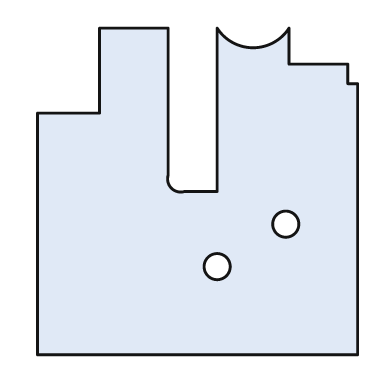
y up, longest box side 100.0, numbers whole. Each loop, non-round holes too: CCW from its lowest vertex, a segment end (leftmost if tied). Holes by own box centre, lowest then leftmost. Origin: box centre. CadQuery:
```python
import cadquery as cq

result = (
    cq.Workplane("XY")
    .moveTo(-49.0, -50.0)
    .lineTo(49.0, -50.0)
    .lineTo(49.0, 33.0)
    .lineTo(46.0, 33.0)
    .lineTo(46.0, 39.0)
    .lineTo(28.0, 39.0)
    .lineTo(28.0, 50.0)
    .threePointArc((17.0, 44.0), (6.0, 50.0))
    .lineTo(6.0, 0.0)
    .lineTo(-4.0, 0.0)
    .threePointArc((-8.0, 1.0), (-9.0, 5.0))
    .lineTo(-9.0, 50.0)
    .lineTo(-30.0, 50.0)
    .lineTo(-30.0, 24.0)
    .lineTo(-49.0, 24.0)
    .close()
    .moveTo(6.0, -23.0)
    .circle(4.0)
    .moveTo(27.0, -10.0)
    .circle(4.0)
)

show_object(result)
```